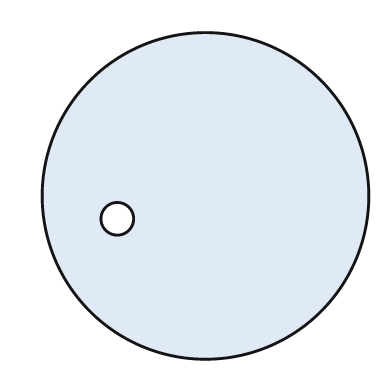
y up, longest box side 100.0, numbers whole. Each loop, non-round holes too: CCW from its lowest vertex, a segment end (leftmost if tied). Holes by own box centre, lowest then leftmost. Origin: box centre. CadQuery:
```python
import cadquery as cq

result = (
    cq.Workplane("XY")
    .moveTo(0.0, 0.0)
    .circle(50.0)
    .moveTo(-27.0, -7.0)
    .circle(5.0)
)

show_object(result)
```